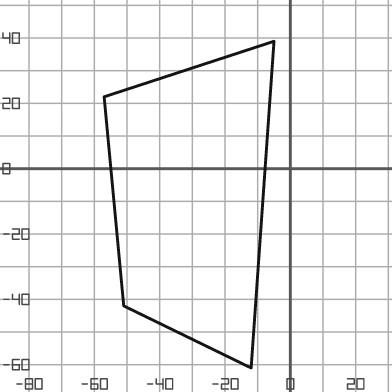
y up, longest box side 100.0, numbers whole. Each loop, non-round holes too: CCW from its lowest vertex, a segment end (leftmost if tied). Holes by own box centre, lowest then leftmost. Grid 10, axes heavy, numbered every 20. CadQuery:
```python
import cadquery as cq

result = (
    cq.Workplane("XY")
    .moveTo(-12.0, -61.0)
    .lineTo(-5.0, 39.0)
    .lineTo(-57.0, 22.0)
    .lineTo(-51.0, -42.0)
    .close()
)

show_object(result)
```